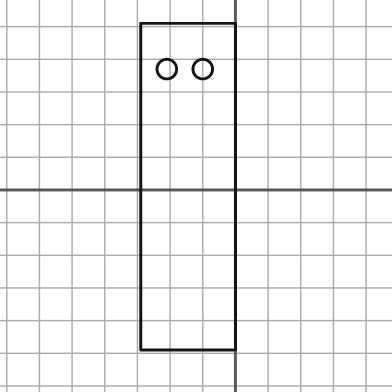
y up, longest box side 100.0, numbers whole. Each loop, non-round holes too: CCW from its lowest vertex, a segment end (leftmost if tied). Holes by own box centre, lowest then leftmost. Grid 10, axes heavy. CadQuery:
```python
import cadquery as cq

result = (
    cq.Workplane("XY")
    .moveTo(-29.0, -49.0)
    .lineTo(0.0, -49.0)
    .lineTo(0.0, 51.0)
    .lineTo(-29.0, 51.0)
    .close()
    .moveTo(-21.0, 37.0)
    .circle(3.0)
    .moveTo(-10.0, 37.0)
    .circle(3.0)
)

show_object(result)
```